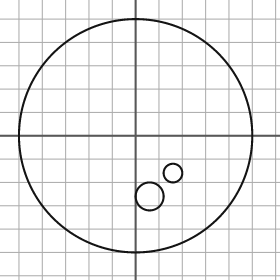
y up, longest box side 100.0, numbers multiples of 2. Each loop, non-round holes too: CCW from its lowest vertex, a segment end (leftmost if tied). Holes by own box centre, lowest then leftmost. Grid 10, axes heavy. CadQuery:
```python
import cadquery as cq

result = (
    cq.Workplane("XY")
    .moveTo(0.0, 0.0)
    .circle(50.0)
    .moveTo(6.0, -26.0)
    .circle(6.0)
    .moveTo(16.0, -16.0)
    .circle(4.0)
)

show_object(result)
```